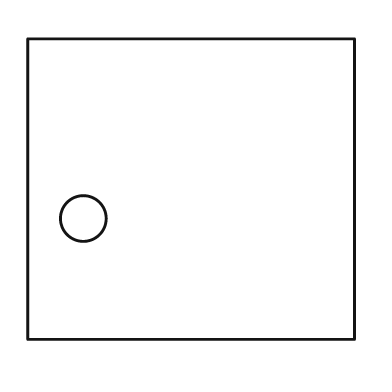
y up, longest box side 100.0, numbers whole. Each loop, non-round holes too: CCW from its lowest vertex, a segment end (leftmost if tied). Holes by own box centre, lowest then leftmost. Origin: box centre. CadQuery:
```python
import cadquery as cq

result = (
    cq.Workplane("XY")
    .moveTo(-50.0, -46.0)
    .lineTo(50.0, -46.0)
    .lineTo(50.0, 46.0)
    .lineTo(-50.0, 46.0)
    .close()
    .moveTo(-33.0, -9.0)
    .circle(7.0)
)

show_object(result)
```